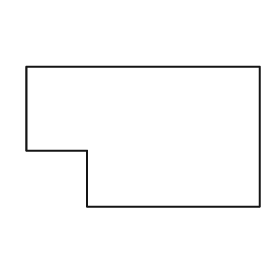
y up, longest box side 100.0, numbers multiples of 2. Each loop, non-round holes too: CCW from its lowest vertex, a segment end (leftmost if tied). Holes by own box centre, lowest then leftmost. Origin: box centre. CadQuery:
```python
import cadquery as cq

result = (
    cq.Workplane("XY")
    .moveTo(-24.0, -30.0)
    .lineTo(50.0, -30.0)
    .lineTo(50.0, 30.0)
    .lineTo(-50.0, 30.0)
    .lineTo(-50.0, -6.0)
    .lineTo(-24.0, -6.0)
    .close()
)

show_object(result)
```